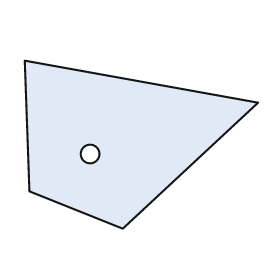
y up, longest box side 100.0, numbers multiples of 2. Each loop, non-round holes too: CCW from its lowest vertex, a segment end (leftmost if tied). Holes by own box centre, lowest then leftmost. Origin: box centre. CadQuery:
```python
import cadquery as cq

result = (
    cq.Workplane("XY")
    .moveTo(-8.0, -36.0)
    .lineTo(50.0, 18.0)
    .lineTo(-50.0, 36.0)
    .lineTo(-48.0, -20.0)
    .close()
    .moveTo(-22.0, -4.0)
    .circle(4.0)
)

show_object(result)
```